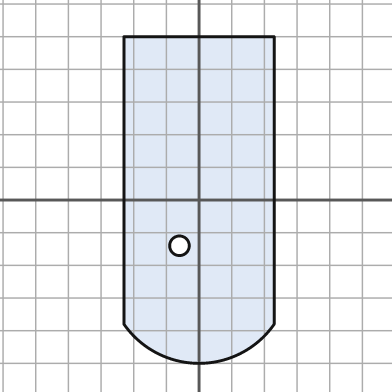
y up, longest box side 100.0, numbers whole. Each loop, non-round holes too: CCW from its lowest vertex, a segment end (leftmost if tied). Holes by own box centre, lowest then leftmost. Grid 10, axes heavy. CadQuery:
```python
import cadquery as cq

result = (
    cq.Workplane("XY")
    .moveTo(-23.0, -38.0)
    .threePointArc((0.0, -50.0), (23.0, -38.0))
    .lineTo(23.0, 50.0)
    .lineTo(-23.0, 50.0)
    .close()
    .moveTo(-6.0, -14.0)
    .circle(3.0)
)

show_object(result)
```